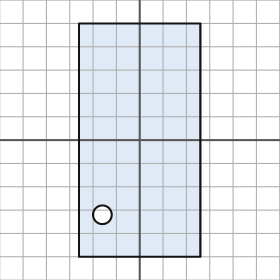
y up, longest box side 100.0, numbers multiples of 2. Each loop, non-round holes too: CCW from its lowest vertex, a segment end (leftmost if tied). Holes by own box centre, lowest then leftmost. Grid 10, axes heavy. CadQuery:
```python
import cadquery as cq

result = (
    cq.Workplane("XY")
    .moveTo(-26.0, -50.0)
    .lineTo(26.0, -50.0)
    .lineTo(26.0, 50.0)
    .lineTo(-26.0, 50.0)
    .close()
    .moveTo(-16.0, -32.0)
    .circle(4.0)
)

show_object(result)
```